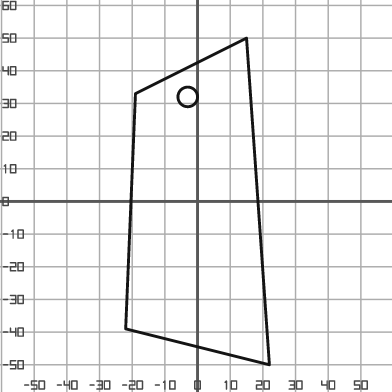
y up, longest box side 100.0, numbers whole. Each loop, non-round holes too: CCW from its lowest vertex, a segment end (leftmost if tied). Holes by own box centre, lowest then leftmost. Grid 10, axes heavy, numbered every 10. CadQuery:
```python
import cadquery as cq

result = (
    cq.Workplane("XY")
    .moveTo(22.0, -50.0)
    .lineTo(15.0, 50.0)
    .lineTo(-19.0, 33.0)
    .lineTo(-22.0, -39.0)
    .close()
    .moveTo(-3.0, 32.0)
    .circle(3.0)
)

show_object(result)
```